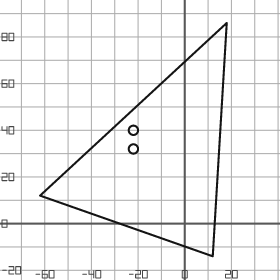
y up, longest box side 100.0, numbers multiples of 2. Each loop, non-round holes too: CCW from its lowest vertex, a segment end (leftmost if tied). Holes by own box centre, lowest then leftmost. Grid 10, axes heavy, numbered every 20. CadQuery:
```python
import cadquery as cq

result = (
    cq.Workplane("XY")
    .moveTo(12.0, -14.0)
    .lineTo(18.0, 86.0)
    .lineTo(-62.0, 12.0)
    .close()
    .moveTo(-22.0, 32.0)
    .circle(2.0)
    .moveTo(-22.0, 40.0)
    .circle(2.0)
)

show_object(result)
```